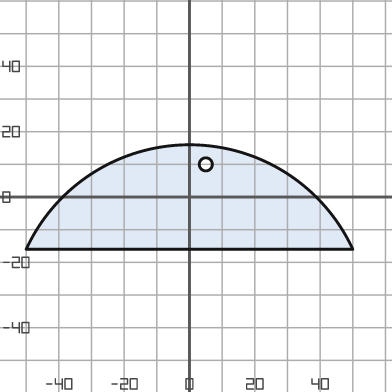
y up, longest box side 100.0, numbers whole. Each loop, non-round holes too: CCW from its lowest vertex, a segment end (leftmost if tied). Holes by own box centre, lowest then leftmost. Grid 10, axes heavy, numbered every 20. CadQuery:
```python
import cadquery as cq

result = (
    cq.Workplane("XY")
    .moveTo(-50.0, -16.0)
    .lineTo(50.0, -16.0)
    .threePointArc((0.0, 16.0), (-50.0, -16.0))
    .close()
    .moveTo(5.0, 10.0)
    .circle(2.0)
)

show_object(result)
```